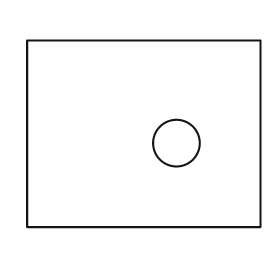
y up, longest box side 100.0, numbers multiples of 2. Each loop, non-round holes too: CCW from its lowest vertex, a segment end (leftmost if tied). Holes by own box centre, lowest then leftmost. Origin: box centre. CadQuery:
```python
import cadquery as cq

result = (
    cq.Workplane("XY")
    .moveTo(-50.0, -40.0)
    .lineTo(50.0, -40.0)
    .lineTo(50.0, 40.0)
    .lineTo(-50.0, 40.0)
    .close()
    .moveTo(14.0, -4.0)
    .circle(10.0)
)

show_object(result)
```